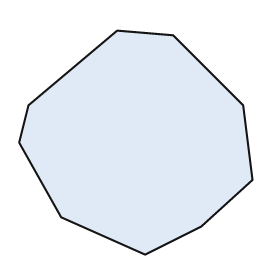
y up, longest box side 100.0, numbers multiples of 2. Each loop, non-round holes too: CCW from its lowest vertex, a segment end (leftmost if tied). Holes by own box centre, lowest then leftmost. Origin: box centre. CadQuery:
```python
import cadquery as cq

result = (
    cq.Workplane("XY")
    .moveTo(4.0, -48.0)
    .lineTo(28.0, -36.0)
    .lineTo(50.0, -16.0)
    .lineTo(46.0, 16.0)
    .lineTo(16.0, 46.0)
    .lineTo(-8.0, 48.0)
    .lineTo(-46.0, 16.0)
    .lineTo(-50.0, 0.0)
    .lineTo(-32.0, -32.0)
    .close()
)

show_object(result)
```